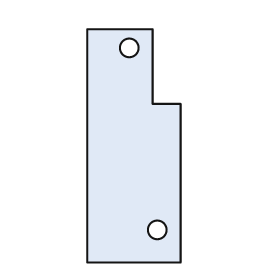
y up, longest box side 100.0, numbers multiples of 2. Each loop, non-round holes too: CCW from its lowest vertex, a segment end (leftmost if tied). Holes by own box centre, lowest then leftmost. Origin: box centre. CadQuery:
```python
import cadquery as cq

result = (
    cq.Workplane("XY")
    .moveTo(-20.0, -50.0)
    .lineTo(20.0, -50.0)
    .lineTo(20.0, 18.0)
    .lineTo(8.0, 18.0)
    .lineTo(8.0, 50.0)
    .lineTo(-20.0, 50.0)
    .close()
    .moveTo(10.0, -36.0)
    .circle(4.0)
    .moveTo(-2.0, 42.0)
    .circle(4.0)
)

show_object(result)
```